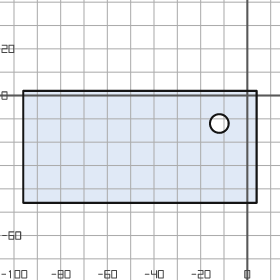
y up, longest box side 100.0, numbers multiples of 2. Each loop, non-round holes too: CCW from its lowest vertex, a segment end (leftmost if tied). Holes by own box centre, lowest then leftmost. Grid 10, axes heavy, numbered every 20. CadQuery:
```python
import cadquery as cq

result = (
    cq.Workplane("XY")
    .moveTo(-96.0, -46.0)
    .lineTo(4.0, -46.0)
    .lineTo(4.0, 2.0)
    .lineTo(-96.0, 2.0)
    .close()
    .moveTo(-12.0, -12.0)
    .circle(4.0)
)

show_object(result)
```